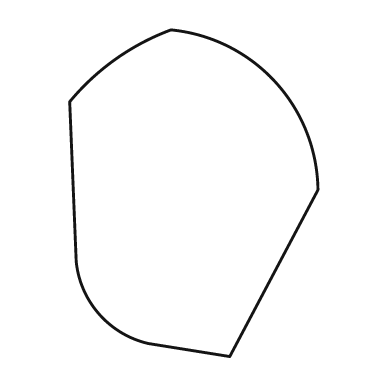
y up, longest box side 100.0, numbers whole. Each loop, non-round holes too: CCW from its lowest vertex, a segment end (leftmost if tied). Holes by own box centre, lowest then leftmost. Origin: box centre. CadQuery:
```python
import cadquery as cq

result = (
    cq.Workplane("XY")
    .moveTo(11.0, -50.0)
    .lineTo(38.0, 1.0)
    .threePointArc((25.0, 34.0), (-7.0, 50.0))
    .threePointArc((-24.0, 41.0), (-38.0, 28.0))
    .lineTo(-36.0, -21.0)
    .threePointArc((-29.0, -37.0), (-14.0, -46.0))
    .close()
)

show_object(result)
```